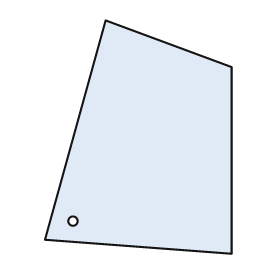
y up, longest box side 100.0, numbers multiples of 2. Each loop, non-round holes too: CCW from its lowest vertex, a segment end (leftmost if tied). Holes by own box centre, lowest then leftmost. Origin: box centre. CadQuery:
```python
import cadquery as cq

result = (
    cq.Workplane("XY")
    .moveTo(40.0, -50.0)
    .lineTo(40.0, 30.0)
    .lineTo(-14.0, 50.0)
    .lineTo(-40.0, -44.0)
    .close()
    .moveTo(-28.0, -36.0)
    .circle(2.0)
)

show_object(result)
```